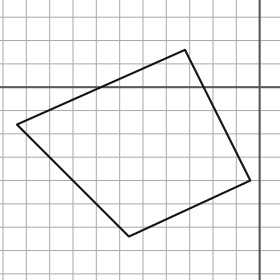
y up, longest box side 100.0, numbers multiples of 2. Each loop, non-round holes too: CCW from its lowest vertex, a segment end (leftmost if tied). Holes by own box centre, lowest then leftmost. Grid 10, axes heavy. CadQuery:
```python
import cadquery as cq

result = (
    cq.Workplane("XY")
    .moveTo(-56.0, -64.0)
    .lineTo(-4.0, -40.0)
    .lineTo(-32.0, 16.0)
    .lineTo(-104.0, -16.0)
    .close()
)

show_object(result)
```